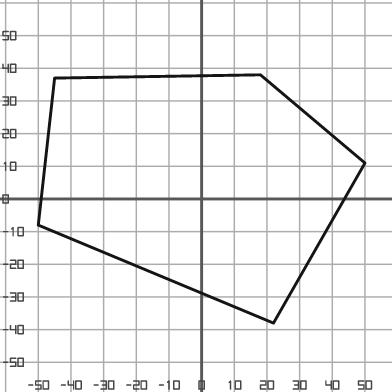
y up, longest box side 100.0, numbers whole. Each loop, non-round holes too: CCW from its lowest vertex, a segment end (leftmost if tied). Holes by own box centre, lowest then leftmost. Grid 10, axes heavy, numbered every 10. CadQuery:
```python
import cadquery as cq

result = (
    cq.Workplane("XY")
    .moveTo(22.0, -38.0)
    .lineTo(50.0, 11.0)
    .lineTo(18.0, 38.0)
    .lineTo(-45.0, 37.0)
    .lineTo(-50.0, -8.0)
    .close()
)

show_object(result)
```